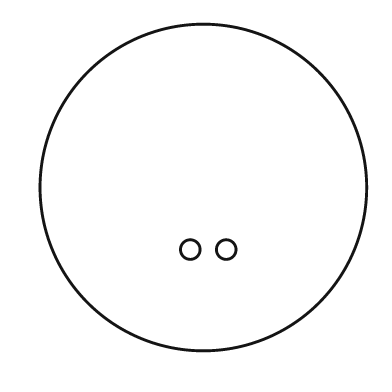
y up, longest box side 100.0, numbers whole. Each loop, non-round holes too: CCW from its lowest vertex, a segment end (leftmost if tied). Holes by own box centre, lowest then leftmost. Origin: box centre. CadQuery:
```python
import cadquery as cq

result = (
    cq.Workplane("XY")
    .moveTo(0.0, 0.0)
    .circle(50.0)
    .moveTo(-4.0, -19.0)
    .circle(3.0)
    .moveTo(7.0, -19.0)
    .circle(3.0)
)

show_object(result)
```